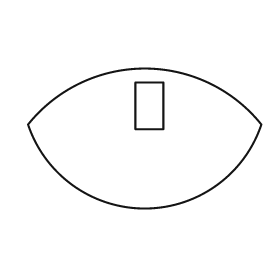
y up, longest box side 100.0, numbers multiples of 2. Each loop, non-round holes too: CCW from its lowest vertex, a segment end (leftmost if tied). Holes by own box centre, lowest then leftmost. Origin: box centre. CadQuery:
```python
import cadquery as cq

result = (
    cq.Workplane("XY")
    .moveTo(-50.0, 6.0)
    .threePointArc((0.0, -30.0), (50.0, 6.0))
    .threePointArc((0.0, 30.0), (-50.0, 6.0))
    .close()
    .moveTo(-4.0, 4.0)
    .lineTo(8.0, 4.0)
    .lineTo(8.0, 24.0)
    .lineTo(-4.0, 24.0)
    .close()
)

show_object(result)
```